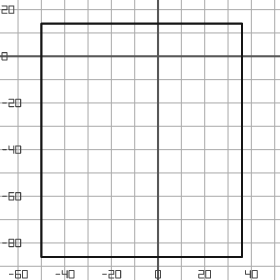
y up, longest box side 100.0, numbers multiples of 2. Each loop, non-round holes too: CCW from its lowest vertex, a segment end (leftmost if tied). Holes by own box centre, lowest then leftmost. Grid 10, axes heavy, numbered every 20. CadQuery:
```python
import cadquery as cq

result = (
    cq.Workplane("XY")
    .moveTo(-50.0, -86.0)
    .lineTo(36.0, -86.0)
    .lineTo(36.0, 14.0)
    .lineTo(-50.0, 14.0)
    .close()
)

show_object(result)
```